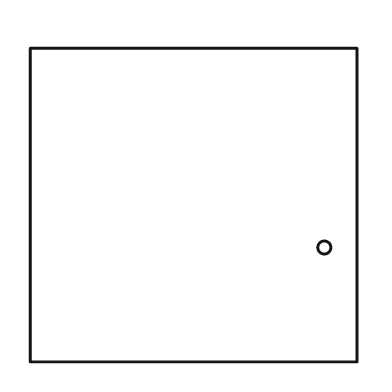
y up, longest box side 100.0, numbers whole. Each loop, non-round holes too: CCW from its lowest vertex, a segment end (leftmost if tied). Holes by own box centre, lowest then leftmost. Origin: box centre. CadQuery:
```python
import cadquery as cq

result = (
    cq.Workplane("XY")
    .moveTo(-50.0, -48.0)
    .lineTo(50.0, -48.0)
    .lineTo(50.0, 48.0)
    .lineTo(-50.0, 48.0)
    .close()
    .moveTo(40.0, -13.0)
    .circle(2.0)
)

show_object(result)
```